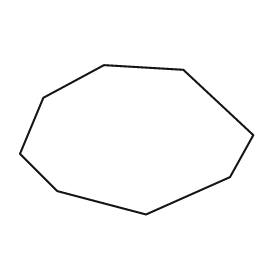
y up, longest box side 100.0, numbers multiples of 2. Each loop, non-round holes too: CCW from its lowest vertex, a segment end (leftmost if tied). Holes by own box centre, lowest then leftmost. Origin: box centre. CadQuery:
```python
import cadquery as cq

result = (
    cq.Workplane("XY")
    .moveTo(4.0, -32.0)
    .lineTo(40.0, -16.0)
    .lineTo(50.0, 2.0)
    .lineTo(20.0, 30.0)
    .lineTo(-14.0, 32.0)
    .lineTo(-40.0, 18.0)
    .lineTo(-50.0, -6.0)
    .lineTo(-34.0, -22.0)
    .close()
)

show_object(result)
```